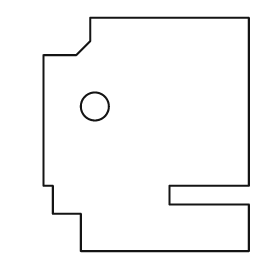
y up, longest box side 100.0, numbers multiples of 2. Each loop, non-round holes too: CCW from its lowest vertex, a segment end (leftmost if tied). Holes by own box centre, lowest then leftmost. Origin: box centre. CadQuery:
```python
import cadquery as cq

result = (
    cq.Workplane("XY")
    .moveTo(-28.0, -50.0)
    .lineTo(44.0, -50.0)
    .lineTo(44.0, -30.0)
    .lineTo(10.0, -30.0)
    .lineTo(10.0, -22.0)
    .lineTo(44.0, -22.0)
    .lineTo(44.0, 50.0)
    .lineTo(-24.0, 50.0)
    .lineTo(-24.0, 40.0)
    .lineTo(-30.0, 34.0)
    .lineTo(-44.0, 34.0)
    .lineTo(-44.0, -22.0)
    .lineTo(-40.0, -22.0)
    .lineTo(-40.0, -34.0)
    .lineTo(-28.0, -34.0)
    .close()
    .moveTo(-22.0, 12.0)
    .circle(6.0)
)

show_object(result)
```